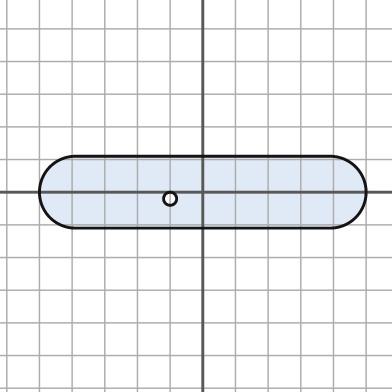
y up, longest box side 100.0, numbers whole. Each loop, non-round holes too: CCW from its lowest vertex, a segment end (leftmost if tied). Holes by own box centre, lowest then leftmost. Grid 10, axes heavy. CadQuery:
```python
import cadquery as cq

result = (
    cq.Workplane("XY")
    .moveTo(-39.0, -11.0)
    .lineTo(39.0, -11.0)
    .threePointArc((50.0, 0.0), (39.0, 11.0))
    .lineTo(-39.0, 11.0)
    .threePointArc((-50.0, 0.0), (-39.0, -11.0))
    .close()
    .moveTo(-10.0, -2.0)
    .circle(2.0)
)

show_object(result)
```